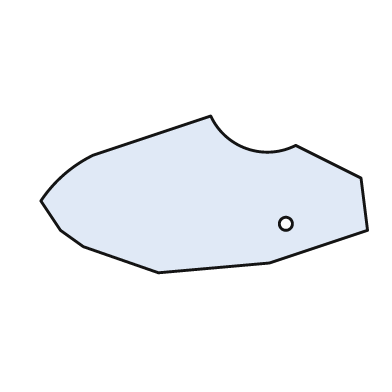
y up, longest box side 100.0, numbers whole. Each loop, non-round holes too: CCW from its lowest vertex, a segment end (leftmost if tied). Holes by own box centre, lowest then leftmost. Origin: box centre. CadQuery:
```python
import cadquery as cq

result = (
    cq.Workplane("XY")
    .moveTo(-14.0, -24.0)
    .lineTo(20.0, -21.0)
    .lineTo(50.0, -11.0)
    .lineTo(48.0, 5.0)
    .lineTo(28.0, 15.0)
    .threePointArc((13.0, 14.0), (2.0, 24.0))
    .lineTo(-34.0, 12.0)
    .threePointArc((-43.0, 6.0), (-50.0, -2.0))
    .lineTo(-44.0, -11.0)
    .lineTo(-37.0, -16.0)
    .close()
    .moveTo(25.0, -9.0)
    .circle(2.0)
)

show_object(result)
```